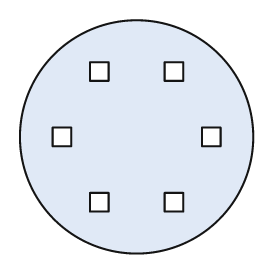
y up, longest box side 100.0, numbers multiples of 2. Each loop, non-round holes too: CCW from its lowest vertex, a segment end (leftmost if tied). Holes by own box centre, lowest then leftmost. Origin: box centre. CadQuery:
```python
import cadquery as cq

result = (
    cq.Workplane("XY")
    .moveTo(0.0, 0.0)
    .circle(50.0)
    .moveTo(-20.0, -32.0)
    .lineTo(-12.0, -32.0)
    .lineTo(-12.0, -24.0)
    .lineTo(-20.0, -24.0)
    .close()
    .moveTo(12.0, -32.0)
    .lineTo(20.0, -32.0)
    .lineTo(20.0, -24.0)
    .lineTo(12.0, -24.0)
    .close()
    .moveTo(-36.0, -4.0)
    .lineTo(-28.0, -4.0)
    .lineTo(-28.0, 4.0)
    .lineTo(-36.0, 4.0)
    .close()
    .moveTo(28.0, -4.0)
    .lineTo(36.0, -4.0)
    .lineTo(36.0, 4.0)
    .lineTo(28.0, 4.0)
    .close()
    .moveTo(-20.0, 24.0)
    .lineTo(-12.0, 24.0)
    .lineTo(-12.0, 32.0)
    .lineTo(-20.0, 32.0)
    .close()
    .moveTo(12.0, 24.0)
    .lineTo(20.0, 24.0)
    .lineTo(20.0, 32.0)
    .lineTo(12.0, 32.0)
    .close()
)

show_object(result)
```